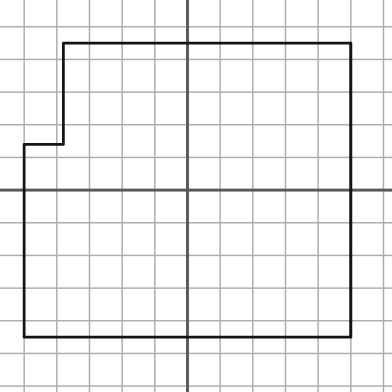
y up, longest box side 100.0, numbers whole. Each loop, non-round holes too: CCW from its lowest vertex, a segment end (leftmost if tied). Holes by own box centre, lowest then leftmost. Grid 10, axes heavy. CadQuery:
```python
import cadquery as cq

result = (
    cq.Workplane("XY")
    .moveTo(-50.0, -45.0)
    .lineTo(50.0, -45.0)
    .lineTo(50.0, 45.0)
    .lineTo(-38.0, 45.0)
    .lineTo(-38.0, 14.0)
    .lineTo(-50.0, 14.0)
    .close()
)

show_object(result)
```